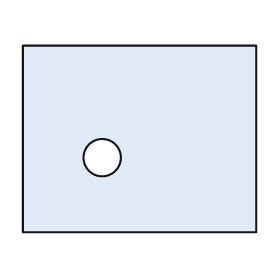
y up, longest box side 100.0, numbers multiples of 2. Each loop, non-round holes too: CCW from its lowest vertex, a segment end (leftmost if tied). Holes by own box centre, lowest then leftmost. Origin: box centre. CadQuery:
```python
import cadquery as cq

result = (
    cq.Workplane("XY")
    .moveTo(-50.0, -40.0)
    .lineTo(50.0, -40.0)
    .lineTo(50.0, 40.0)
    .lineTo(-50.0, 40.0)
    .close()
    .moveTo(-16.0, -8.0)
    .circle(8.0)
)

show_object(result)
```